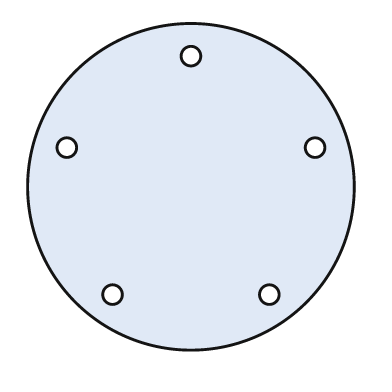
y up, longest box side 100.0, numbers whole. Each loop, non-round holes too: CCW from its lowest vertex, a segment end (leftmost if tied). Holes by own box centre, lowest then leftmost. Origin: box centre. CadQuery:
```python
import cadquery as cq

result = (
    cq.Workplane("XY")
    .moveTo(0.0, 0.0)
    .circle(50.0)
    .moveTo(-24.0, -33.0)
    .circle(3.0)
    .moveTo(24.0, -33.0)
    .circle(3.0)
    .moveTo(-38.0, 12.0)
    .circle(3.0)
    .moveTo(38.0, 12.0)
    .circle(3.0)
    .moveTo(0.0, 40.0)
    .circle(3.0)
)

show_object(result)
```